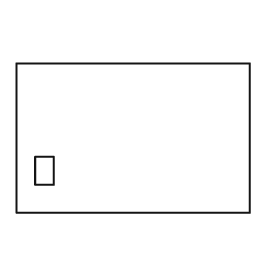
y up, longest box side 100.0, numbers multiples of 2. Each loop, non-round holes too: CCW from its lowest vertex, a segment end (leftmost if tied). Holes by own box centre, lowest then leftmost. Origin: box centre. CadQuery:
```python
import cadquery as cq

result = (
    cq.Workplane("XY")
    .moveTo(-50.0, -32.0)
    .lineTo(50.0, -32.0)
    .lineTo(50.0, 32.0)
    .lineTo(-50.0, 32.0)
    .close()
    .moveTo(-42.0, -20.0)
    .lineTo(-34.0, -20.0)
    .lineTo(-34.0, -8.0)
    .lineTo(-42.0, -8.0)
    .close()
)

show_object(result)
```